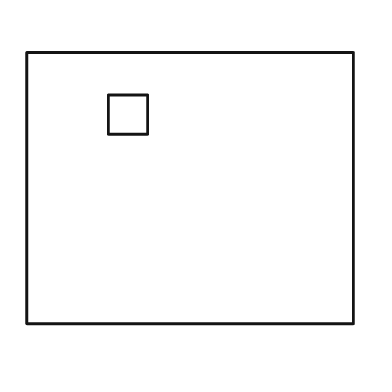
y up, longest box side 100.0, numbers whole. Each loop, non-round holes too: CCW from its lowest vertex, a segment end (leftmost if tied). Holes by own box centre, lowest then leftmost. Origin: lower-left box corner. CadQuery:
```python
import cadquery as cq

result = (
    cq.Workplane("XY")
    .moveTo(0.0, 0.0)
    .lineTo(100.0, 0.0)
    .lineTo(100.0, 83.0)
    .lineTo(0.0, 83.0)
    .close()
    .moveTo(25.0, 58.0)
    .lineTo(37.0, 58.0)
    .lineTo(37.0, 70.0)
    .lineTo(25.0, 70.0)
    .close()
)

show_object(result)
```